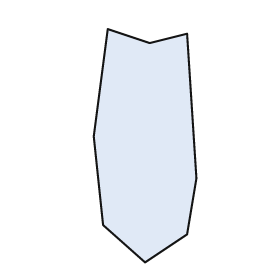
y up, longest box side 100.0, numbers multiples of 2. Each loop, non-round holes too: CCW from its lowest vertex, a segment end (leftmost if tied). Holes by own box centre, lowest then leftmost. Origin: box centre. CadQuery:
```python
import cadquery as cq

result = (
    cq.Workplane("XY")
    .moveTo(0.0, -50.0)
    .lineTo(18.0, -38.0)
    .lineTo(22.0, -14.0)
    .lineTo(18.0, 48.0)
    .lineTo(2.0, 44.0)
    .lineTo(-16.0, 50.0)
    .lineTo(-22.0, 4.0)
    .lineTo(-18.0, -34.0)
    .close()
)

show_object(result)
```